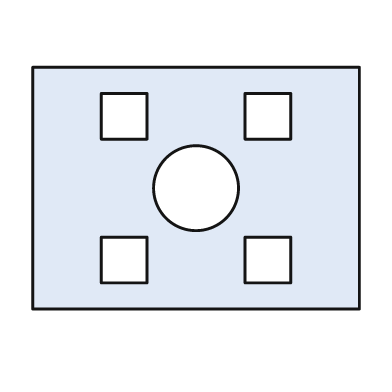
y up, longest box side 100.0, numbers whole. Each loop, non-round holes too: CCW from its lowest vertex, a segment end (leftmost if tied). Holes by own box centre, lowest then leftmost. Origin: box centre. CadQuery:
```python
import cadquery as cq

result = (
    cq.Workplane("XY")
    .moveTo(-50.0, -37.0)
    .lineTo(50.0, -37.0)
    .lineTo(50.0, 37.0)
    .lineTo(-50.0, 37.0)
    .close()
    .moveTo(-29.0, -29.0)
    .lineTo(-15.0, -29.0)
    .lineTo(-15.0, -15.0)
    .lineTo(-29.0, -15.0)
    .close()
    .moveTo(15.0, -29.0)
    .lineTo(29.0, -29.0)
    .lineTo(29.0, -15.0)
    .lineTo(15.0, -15.0)
    .close()
    .moveTo(0.0, 0.0)
    .circle(13.0)
    .moveTo(-29.0, 15.0)
    .lineTo(-15.0, 15.0)
    .lineTo(-15.0, 29.0)
    .lineTo(-29.0, 29.0)
    .close()
    .moveTo(15.0, 15.0)
    .lineTo(29.0, 15.0)
    .lineTo(29.0, 29.0)
    .lineTo(15.0, 29.0)
    .close()
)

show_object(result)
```